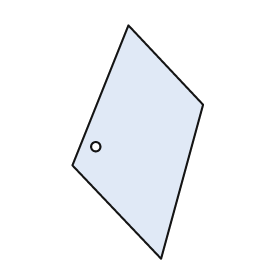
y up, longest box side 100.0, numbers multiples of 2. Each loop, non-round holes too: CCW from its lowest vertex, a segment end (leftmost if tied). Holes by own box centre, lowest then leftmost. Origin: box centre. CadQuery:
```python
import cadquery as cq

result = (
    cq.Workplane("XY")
    .moveTo(10.0, -50.0)
    .lineTo(28.0, 16.0)
    .lineTo(-4.0, 50.0)
    .lineTo(-28.0, -10.0)
    .close()
    .moveTo(-18.0, -2.0)
    .circle(2.0)
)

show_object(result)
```